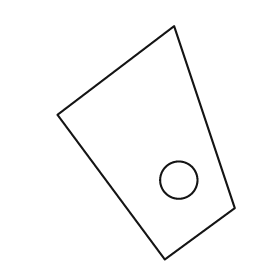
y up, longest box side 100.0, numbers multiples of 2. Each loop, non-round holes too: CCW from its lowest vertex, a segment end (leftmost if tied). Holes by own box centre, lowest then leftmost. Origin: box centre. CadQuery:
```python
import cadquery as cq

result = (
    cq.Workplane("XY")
    .moveTo(8.0, -50.0)
    .lineTo(38.0, -28.0)
    .lineTo(12.0, 50.0)
    .lineTo(-38.0, 12.0)
    .close()
    .moveTo(14.0, -16.0)
    .circle(8.0)
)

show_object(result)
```